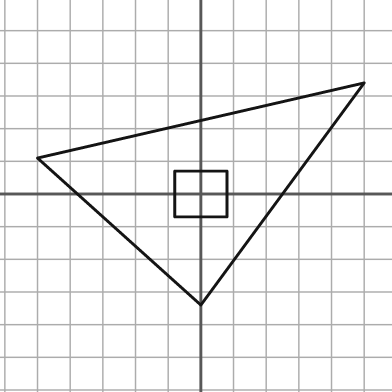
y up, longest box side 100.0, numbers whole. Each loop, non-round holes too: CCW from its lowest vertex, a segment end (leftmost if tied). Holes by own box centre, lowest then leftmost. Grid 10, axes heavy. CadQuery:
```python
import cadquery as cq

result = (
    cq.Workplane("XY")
    .moveTo(0.0, -34.0)
    .lineTo(50.0, 34.0)
    .lineTo(-50.0, 11.0)
    .close()
    .moveTo(-8.0, -7.0)
    .lineTo(8.0, -7.0)
    .lineTo(8.0, 7.0)
    .lineTo(-8.0, 7.0)
    .close()
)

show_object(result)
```